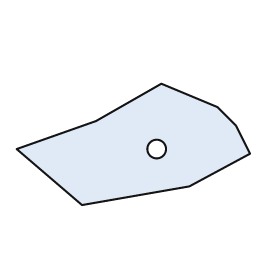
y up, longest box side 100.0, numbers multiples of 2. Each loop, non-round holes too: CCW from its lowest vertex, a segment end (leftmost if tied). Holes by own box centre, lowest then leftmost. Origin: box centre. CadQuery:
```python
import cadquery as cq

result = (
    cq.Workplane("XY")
    .moveTo(-22.0, -26.0)
    .lineTo(24.0, -18.0)
    .lineTo(50.0, -4.0)
    .lineTo(44.0, 8.0)
    .lineTo(36.0, 16.0)
    .lineTo(12.0, 26.0)
    .lineTo(-16.0, 10.0)
    .lineTo(-50.0, -2.0)
    .close()
    .moveTo(10.0, -2.0)
    .circle(4.0)
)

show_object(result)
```